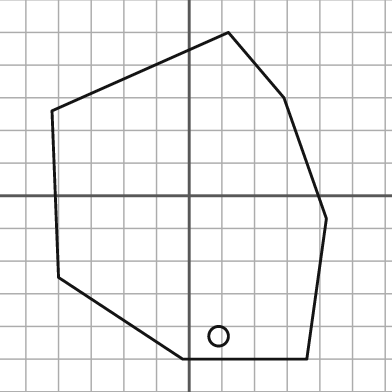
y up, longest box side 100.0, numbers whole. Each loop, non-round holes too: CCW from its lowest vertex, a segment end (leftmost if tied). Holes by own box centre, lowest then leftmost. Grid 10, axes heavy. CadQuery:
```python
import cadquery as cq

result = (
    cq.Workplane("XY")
    .moveTo(-2.0, -50.0)
    .lineTo(36.0, -50.0)
    .lineTo(42.0, -7.0)
    .lineTo(29.0, 30.0)
    .lineTo(12.0, 50.0)
    .lineTo(-42.0, 26.0)
    .lineTo(-40.0, -25.0)
    .close()
    .moveTo(9.0, -43.0)
    .circle(3.0)
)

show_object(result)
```